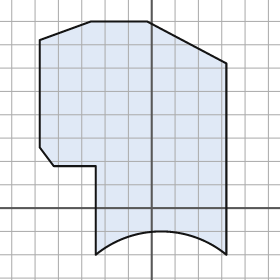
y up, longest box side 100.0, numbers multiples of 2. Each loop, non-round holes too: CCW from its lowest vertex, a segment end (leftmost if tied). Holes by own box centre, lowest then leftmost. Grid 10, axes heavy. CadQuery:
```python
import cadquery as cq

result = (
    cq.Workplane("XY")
    .moveTo(-24.0, -20.0)
    .threePointArc((4.0, -10.0), (32.0, -20.0))
    .lineTo(32.0, 62.0)
    .lineTo(-2.0, 80.0)
    .lineTo(-26.0, 80.0)
    .lineTo(-48.0, 72.0)
    .lineTo(-48.0, 26.0)
    .lineTo(-42.0, 18.0)
    .lineTo(-24.0, 18.0)
    .close()
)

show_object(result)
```